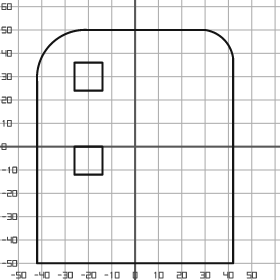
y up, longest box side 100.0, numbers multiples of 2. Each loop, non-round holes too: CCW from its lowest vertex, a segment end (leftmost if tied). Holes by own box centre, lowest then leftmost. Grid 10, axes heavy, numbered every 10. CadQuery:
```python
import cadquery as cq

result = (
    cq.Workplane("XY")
    .moveTo(-42.0, -50.0)
    .lineTo(42.0, -50.0)
    .lineTo(42.0, 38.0)
    .threePointArc((38.0, 46.0), (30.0, 50.0))
    .lineTo(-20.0, 50.0)
    .threePointArc((-36.0, 44.0), (-42.0, 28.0))
    .close()
    .moveTo(-26.0, -12.0)
    .lineTo(-14.0, -12.0)
    .lineTo(-14.0, 0.0)
    .lineTo(-26.0, 0.0)
    .close()
    .moveTo(-26.0, 24.0)
    .lineTo(-14.0, 24.0)
    .lineTo(-14.0, 36.0)
    .lineTo(-26.0, 36.0)
    .close()
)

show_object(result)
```